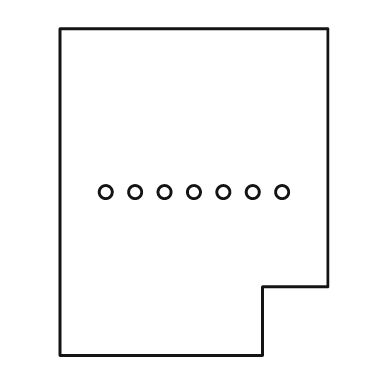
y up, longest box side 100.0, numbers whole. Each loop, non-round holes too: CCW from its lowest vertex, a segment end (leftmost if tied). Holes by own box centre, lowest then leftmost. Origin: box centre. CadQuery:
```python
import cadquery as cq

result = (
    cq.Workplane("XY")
    .moveTo(-41.0, -50.0)
    .lineTo(21.0, -50.0)
    .lineTo(21.0, -29.0)
    .lineTo(41.0, -29.0)
    .lineTo(41.0, 50.0)
    .lineTo(-41.0, 50.0)
    .close()
    .moveTo(-27.0, 0.0)
    .circle(2.0)
    .moveTo(-18.0, 0.0)
    .circle(2.0)
    .moveTo(-9.0, 0.0)
    .circle(2.0)
    .moveTo(0.0, 0.0)
    .circle(2.0)
    .moveTo(9.0, 0.0)
    .circle(2.0)
    .moveTo(18.0, 0.0)
    .circle(2.0)
    .moveTo(27.0, 0.0)
    .circle(2.0)
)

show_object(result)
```